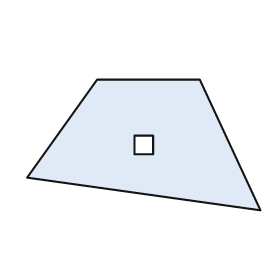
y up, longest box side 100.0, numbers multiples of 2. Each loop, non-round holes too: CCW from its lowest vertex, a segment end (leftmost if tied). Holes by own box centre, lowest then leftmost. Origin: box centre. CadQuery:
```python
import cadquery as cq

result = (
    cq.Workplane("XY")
    .moveTo(50.0, -28.0)
    .lineTo(24.0, 28.0)
    .lineTo(-20.0, 28.0)
    .lineTo(-50.0, -14.0)
    .close()
    .moveTo(-4.0, -4.0)
    .lineTo(4.0, -4.0)
    .lineTo(4.0, 4.0)
    .lineTo(-4.0, 4.0)
    .close()
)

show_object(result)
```